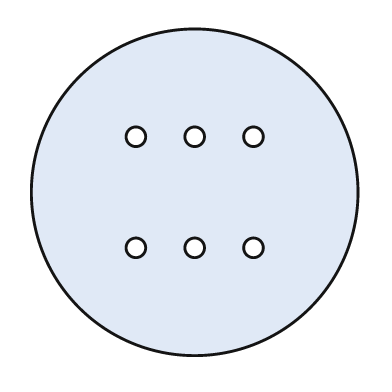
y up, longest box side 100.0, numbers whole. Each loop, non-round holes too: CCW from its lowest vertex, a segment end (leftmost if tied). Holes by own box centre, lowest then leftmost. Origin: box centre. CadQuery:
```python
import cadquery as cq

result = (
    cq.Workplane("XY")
    .moveTo(0.0, 0.0)
    .circle(50.0)
    .moveTo(-18.0, -17.0)
    .circle(3.0)
    .moveTo(0.0, -17.0)
    .circle(3.0)
    .moveTo(18.0, -17.0)
    .circle(3.0)
    .moveTo(-18.0, 17.0)
    .circle(3.0)
    .moveTo(0.0, 17.0)
    .circle(3.0)
    .moveTo(18.0, 17.0)
    .circle(3.0)
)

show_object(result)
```